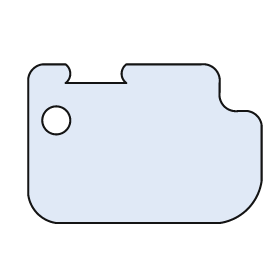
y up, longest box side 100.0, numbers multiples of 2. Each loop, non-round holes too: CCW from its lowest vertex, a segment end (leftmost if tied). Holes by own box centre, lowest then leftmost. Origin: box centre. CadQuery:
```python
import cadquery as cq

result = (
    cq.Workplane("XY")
    .moveTo(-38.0, -34.0)
    .lineTo(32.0, -34.0)
    .threePointArc((44.0, -28.0), (50.0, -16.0))
    .lineTo(50.0, 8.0)
    .threePointArc((48.0, 12.0), (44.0, 14.0))
    .lineTo(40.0, 14.0)
    .threePointArc((34.0, 16.0), (32.0, 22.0))
    .lineTo(32.0, 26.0)
    .threePointArc((30.0, 32.0), (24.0, 34.0))
    .lineTo(-8.0, 34.0)
    .threePointArc((-10.0, 30.0), (-8.0, 26.0))
    .lineTo(-34.0, 26.0)
    .threePointArc((-32.0, 30.0), (-34.0, 34.0))
    .lineTo(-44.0, 34.0)
    .threePointArc((-48.0, 32.0), (-50.0, 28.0))
    .lineTo(-50.0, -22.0)
    .threePointArc((-46.0, -30.0), (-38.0, -34.0))
    .close()
    .moveTo(-38.0, 10.0)
    .circle(6.0)
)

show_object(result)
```